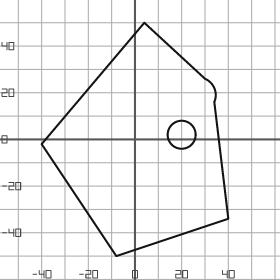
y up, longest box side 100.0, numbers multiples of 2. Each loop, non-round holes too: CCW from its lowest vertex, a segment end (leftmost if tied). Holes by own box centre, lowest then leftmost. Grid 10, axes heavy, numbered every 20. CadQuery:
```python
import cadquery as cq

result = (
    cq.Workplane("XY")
    .moveTo(-8.0, -50.0)
    .lineTo(40.0, -34.0)
    .lineTo(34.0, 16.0)
    .threePointArc((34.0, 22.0), (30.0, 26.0))
    .lineTo(4.0, 50.0)
    .lineTo(-40.0, -2.0)
    .close()
    .moveTo(20.0, 2.0)
    .circle(6.0)
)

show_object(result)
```